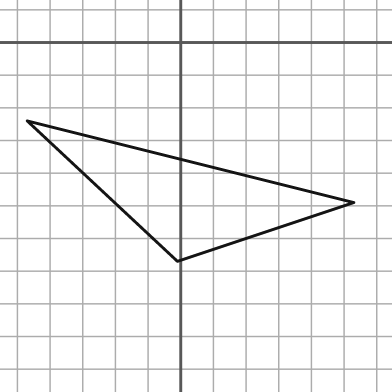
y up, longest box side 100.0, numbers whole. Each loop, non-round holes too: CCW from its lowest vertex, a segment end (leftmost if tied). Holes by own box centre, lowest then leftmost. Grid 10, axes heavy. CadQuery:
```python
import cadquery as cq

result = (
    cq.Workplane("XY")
    .moveTo(-1.0, -67.0)
    .lineTo(53.0, -49.0)
    .lineTo(-47.0, -24.0)
    .close()
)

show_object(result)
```